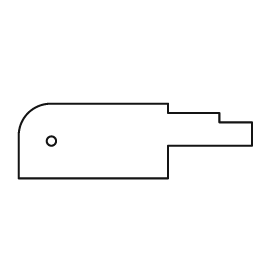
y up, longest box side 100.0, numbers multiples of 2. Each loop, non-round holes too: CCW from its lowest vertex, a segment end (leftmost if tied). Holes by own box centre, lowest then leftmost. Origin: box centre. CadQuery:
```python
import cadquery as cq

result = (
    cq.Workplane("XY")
    .moveTo(-50.0, -16.0)
    .lineTo(14.0, -16.0)
    .lineTo(14.0, -2.0)
    .lineTo(50.0, -2.0)
    .lineTo(50.0, 8.0)
    .lineTo(36.0, 8.0)
    .lineTo(36.0, 12.0)
    .lineTo(14.0, 12.0)
    .lineTo(14.0, 16.0)
    .lineTo(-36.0, 16.0)
    .threePointArc((-46.0, 12.0), (-50.0, 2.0))
    .close()
    .moveTo(-36.0, 0.0)
    .circle(2.0)
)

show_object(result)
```